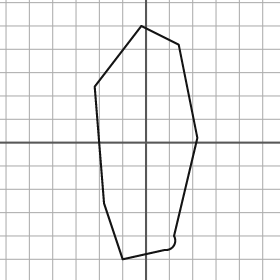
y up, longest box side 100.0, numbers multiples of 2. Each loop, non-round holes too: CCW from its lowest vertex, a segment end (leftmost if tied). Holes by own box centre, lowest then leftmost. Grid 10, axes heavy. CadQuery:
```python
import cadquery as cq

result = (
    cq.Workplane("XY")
    .moveTo(-10.0, -50.0)
    .lineTo(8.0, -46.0)
    .threePointArc((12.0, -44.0), (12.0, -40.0))
    .lineTo(22.0, 2.0)
    .lineTo(14.0, 42.0)
    .lineTo(-2.0, 50.0)
    .lineTo(-22.0, 24.0)
    .lineTo(-18.0, -26.0)
    .close()
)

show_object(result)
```